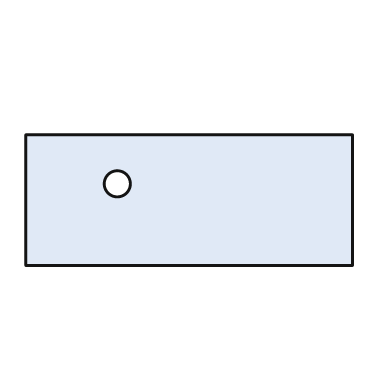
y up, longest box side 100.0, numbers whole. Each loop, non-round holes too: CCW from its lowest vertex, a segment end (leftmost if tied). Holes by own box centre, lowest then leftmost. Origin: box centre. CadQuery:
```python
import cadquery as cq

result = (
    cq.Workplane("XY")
    .moveTo(-50.0, -20.0)
    .lineTo(50.0, -20.0)
    .lineTo(50.0, 20.0)
    .lineTo(-50.0, 20.0)
    .close()
    .moveTo(-22.0, 5.0)
    .circle(4.0)
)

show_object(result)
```